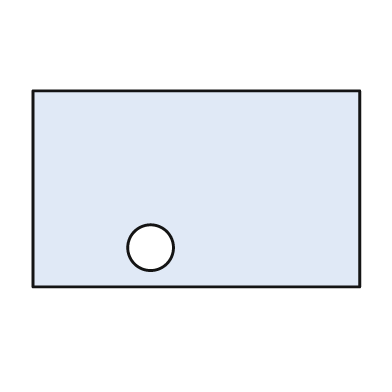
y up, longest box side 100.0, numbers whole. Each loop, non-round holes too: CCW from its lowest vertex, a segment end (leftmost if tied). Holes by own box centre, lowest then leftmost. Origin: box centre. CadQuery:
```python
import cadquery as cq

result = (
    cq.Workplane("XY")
    .moveTo(-50.0, -30.0)
    .lineTo(50.0, -30.0)
    .lineTo(50.0, 30.0)
    .lineTo(-50.0, 30.0)
    .close()
    .moveTo(-14.0, -18.0)
    .circle(7.0)
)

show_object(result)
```